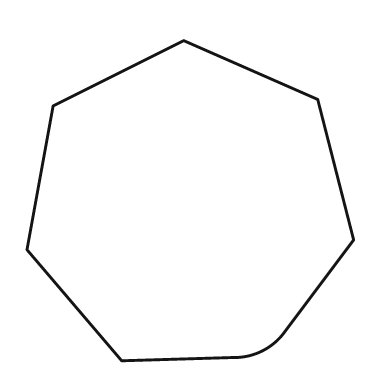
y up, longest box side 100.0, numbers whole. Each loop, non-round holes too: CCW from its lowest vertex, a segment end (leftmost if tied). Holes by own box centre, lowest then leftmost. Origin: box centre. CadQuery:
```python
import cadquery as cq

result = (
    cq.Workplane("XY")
    .moveTo(-21.0, -49.0)
    .lineTo(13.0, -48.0)
    .threePointArc((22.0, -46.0), (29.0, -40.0))
    .lineTo(50.0, -12.0)
    .lineTo(39.0, 31.0)
    .lineTo(-2.0, 49.0)
    .lineTo(-42.0, 29.0)
    .lineTo(-50.0, -15.0)
    .close()
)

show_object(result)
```